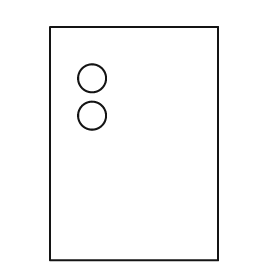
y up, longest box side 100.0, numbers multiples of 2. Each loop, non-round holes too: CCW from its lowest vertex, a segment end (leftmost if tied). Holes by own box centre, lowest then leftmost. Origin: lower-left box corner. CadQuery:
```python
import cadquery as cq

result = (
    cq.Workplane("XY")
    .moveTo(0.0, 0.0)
    .lineTo(72.0, 0.0)
    .lineTo(72.0, 100.0)
    .lineTo(0.0, 100.0)
    .close()
    .moveTo(18.0, 62.0)
    .circle(6.0)
    .moveTo(18.0, 78.0)
    .circle(6.0)
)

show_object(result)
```